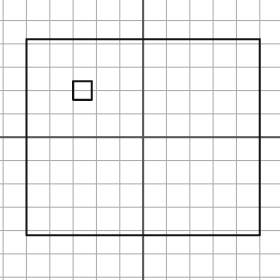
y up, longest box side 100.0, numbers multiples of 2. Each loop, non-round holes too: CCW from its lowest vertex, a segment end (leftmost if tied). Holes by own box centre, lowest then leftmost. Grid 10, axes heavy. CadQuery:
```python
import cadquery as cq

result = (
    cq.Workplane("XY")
    .moveTo(-50.0, -42.0)
    .lineTo(50.0, -42.0)
    .lineTo(50.0, 42.0)
    .lineTo(-50.0, 42.0)
    .close()
    .moveTo(-30.0, 16.0)
    .lineTo(-22.0, 16.0)
    .lineTo(-22.0, 24.0)
    .lineTo(-30.0, 24.0)
    .close()
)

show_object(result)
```